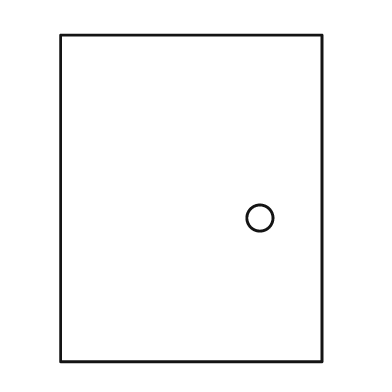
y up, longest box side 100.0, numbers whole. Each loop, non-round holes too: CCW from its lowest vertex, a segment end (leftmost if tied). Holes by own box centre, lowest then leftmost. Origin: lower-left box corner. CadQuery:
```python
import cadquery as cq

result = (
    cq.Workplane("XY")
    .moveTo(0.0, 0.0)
    .lineTo(80.0, 0.0)
    .lineTo(80.0, 100.0)
    .lineTo(0.0, 100.0)
    .close()
    .moveTo(61.0, 44.0)
    .circle(4.0)
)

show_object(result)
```